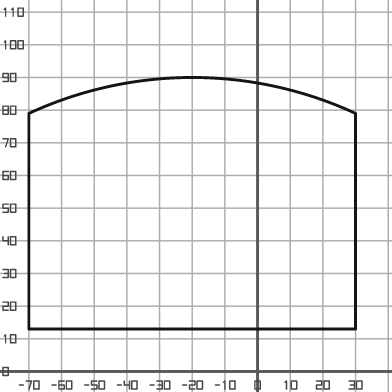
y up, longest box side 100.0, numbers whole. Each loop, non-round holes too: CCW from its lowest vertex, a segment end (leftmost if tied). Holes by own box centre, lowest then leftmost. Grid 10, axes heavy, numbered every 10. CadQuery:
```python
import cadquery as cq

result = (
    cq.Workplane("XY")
    .moveTo(-70.0, 13.0)
    .lineTo(30.0, 13.0)
    .lineTo(30.0, 79.0)
    .threePointArc((-20.0, 90.0), (-70.0, 79.0))
    .close()
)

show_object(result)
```